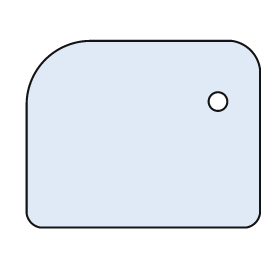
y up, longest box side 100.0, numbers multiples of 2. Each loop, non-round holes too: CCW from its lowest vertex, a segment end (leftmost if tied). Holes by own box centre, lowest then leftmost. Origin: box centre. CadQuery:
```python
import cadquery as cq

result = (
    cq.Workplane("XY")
    .moveTo(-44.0, -40.0)
    .lineTo(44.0, -40.0)
    .threePointArc((48.0, -38.0), (50.0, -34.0))
    .lineTo(50.0, 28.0)
    .threePointArc((46.0, 36.0), (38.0, 40.0))
    .lineTo(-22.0, 40.0)
    .threePointArc((-42.0, 32.0), (-50.0, 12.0))
    .lineTo(-50.0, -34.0)
    .threePointArc((-48.0, -38.0), (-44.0, -40.0))
    .close()
    .moveTo(32.0, 14.0)
    .circle(4.0)
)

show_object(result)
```